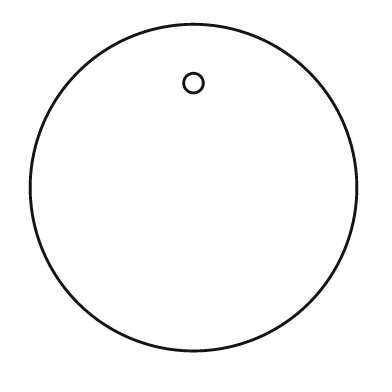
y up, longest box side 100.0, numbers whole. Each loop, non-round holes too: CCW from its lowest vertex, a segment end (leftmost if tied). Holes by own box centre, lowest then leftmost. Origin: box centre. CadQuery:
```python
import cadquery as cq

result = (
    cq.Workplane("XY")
    .moveTo(0.0, 0.0)
    .circle(50.0)
    .moveTo(0.0, 32.0)
    .circle(3.0)
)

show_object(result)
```